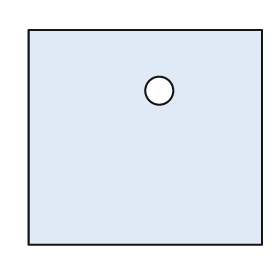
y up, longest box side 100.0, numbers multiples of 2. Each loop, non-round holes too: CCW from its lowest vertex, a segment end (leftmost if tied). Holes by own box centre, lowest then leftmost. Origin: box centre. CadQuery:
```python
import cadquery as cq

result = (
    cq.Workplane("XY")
    .moveTo(-50.0, -46.0)
    .lineTo(50.0, -46.0)
    .lineTo(50.0, 46.0)
    .lineTo(-50.0, 46.0)
    .close()
    .moveTo(6.0, 20.0)
    .circle(6.0)
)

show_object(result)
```